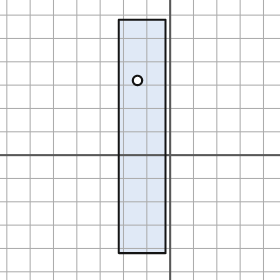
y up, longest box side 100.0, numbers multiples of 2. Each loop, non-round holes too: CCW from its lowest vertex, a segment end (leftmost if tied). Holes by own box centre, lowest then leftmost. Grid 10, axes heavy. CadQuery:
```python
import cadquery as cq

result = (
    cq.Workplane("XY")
    .moveTo(-22.0, -42.0)
    .lineTo(-2.0, -42.0)
    .lineTo(-2.0, 58.0)
    .lineTo(-22.0, 58.0)
    .close()
    .moveTo(-14.0, 32.0)
    .circle(2.0)
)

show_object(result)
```